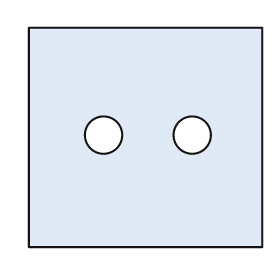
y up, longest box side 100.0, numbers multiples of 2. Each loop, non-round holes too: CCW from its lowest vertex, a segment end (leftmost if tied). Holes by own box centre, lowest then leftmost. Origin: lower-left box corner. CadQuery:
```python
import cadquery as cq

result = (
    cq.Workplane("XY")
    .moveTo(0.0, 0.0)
    .lineTo(100.0, 0.0)
    .lineTo(100.0, 94.0)
    .lineTo(0.0, 94.0)
    .close()
    .moveTo(32.0, 48.0)
    .circle(8.0)
    .moveTo(70.0, 48.0)
    .circle(8.0)
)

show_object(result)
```